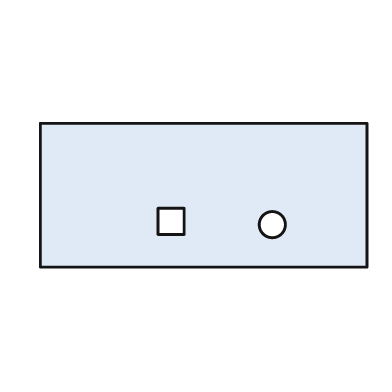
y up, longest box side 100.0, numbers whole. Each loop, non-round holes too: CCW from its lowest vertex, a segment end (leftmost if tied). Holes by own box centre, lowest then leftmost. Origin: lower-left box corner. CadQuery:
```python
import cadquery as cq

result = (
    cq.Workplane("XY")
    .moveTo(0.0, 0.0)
    .lineTo(100.0, 0.0)
    .lineTo(100.0, 44.0)
    .lineTo(0.0, 44.0)
    .close()
    .moveTo(71.0, 13.0)
    .circle(4.0)
    .moveTo(36.0, 10.0)
    .lineTo(44.0, 10.0)
    .lineTo(44.0, 18.0)
    .lineTo(36.0, 18.0)
    .close()
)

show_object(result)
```